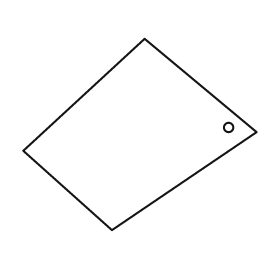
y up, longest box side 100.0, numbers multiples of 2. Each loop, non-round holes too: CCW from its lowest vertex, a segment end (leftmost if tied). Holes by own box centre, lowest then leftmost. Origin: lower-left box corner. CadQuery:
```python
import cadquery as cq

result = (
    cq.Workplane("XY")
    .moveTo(38.0, 0.0)
    .lineTo(100.0, 42.0)
    .lineTo(52.0, 82.0)
    .lineTo(0.0, 34.0)
    .close()
    .moveTo(88.0, 44.0)
    .circle(2.0)
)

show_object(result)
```